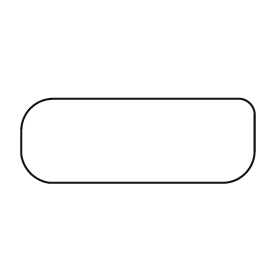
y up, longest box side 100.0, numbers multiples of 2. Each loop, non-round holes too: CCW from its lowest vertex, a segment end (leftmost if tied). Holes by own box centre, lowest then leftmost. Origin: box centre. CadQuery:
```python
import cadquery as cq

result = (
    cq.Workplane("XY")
    .moveTo(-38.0, -18.0)
    .lineTo(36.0, -18.0)
    .threePointArc((46.0, -14.0), (50.0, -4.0))
    .lineTo(50.0, 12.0)
    .threePointArc((48.0, 16.0), (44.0, 18.0))
    .lineTo(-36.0, 18.0)
    .threePointArc((-46.0, 14.0), (-50.0, 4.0))
    .lineTo(-50.0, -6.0)
    .threePointArc((-46.0, -14.0), (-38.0, -18.0))
    .close()
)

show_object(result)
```